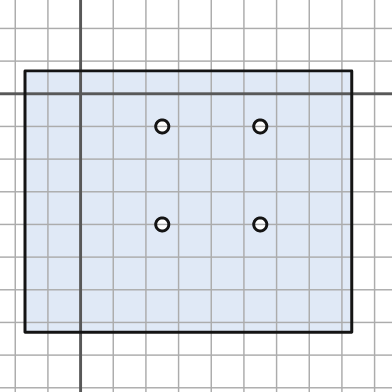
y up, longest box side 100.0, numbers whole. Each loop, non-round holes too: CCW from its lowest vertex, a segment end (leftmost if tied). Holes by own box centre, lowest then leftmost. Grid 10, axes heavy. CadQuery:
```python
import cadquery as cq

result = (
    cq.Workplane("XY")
    .moveTo(-17.0, -73.0)
    .lineTo(83.0, -73.0)
    .lineTo(83.0, 7.0)
    .lineTo(-17.0, 7.0)
    .close()
    .moveTo(25.0, -40.0)
    .circle(2.0)
    .moveTo(55.0, -40.0)
    .circle(2.0)
    .moveTo(25.0, -10.0)
    .circle(2.0)
    .moveTo(55.0, -10.0)
    .circle(2.0)
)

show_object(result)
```